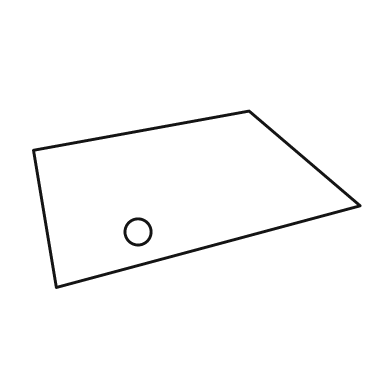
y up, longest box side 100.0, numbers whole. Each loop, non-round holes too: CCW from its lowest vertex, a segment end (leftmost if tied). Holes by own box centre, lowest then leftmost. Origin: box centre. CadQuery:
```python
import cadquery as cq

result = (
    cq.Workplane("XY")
    .moveTo(-43.0, -27.0)
    .lineTo(50.0, -2.0)
    .lineTo(16.0, 27.0)
    .lineTo(-50.0, 15.0)
    .close()
    .moveTo(-18.0, -10.0)
    .circle(4.0)
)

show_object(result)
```